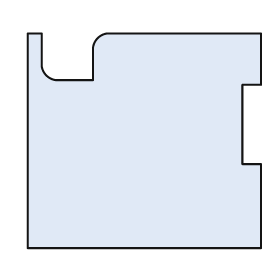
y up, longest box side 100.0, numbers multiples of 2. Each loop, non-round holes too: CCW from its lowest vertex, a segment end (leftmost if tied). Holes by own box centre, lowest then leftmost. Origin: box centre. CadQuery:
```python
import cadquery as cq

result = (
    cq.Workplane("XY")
    .moveTo(-50.0, -46.0)
    .lineTo(50.0, -46.0)
    .lineTo(50.0, -10.0)
    .lineTo(42.0, -10.0)
    .lineTo(42.0, 24.0)
    .lineTo(50.0, 24.0)
    .lineTo(50.0, 46.0)
    .lineTo(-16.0, 46.0)
    .threePointArc((-20.0, 44.0), (-22.0, 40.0))
    .lineTo(-22.0, 26.0)
    .lineTo(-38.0, 26.0)
    .threePointArc((-42.0, 28.0), (-44.0, 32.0))
    .lineTo(-44.0, 46.0)
    .lineTo(-50.0, 46.0)
    .close()
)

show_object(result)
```